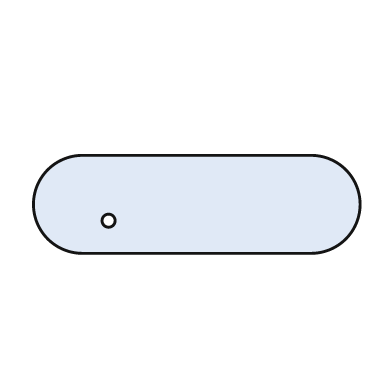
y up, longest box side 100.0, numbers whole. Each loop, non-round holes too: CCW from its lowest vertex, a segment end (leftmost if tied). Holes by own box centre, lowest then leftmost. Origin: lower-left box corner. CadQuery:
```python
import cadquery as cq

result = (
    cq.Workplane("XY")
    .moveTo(15.0, 0.0)
    .lineTo(85.0, 0.0)
    .threePointArc((100.0, 15.0), (85.0, 30.0))
    .lineTo(15.0, 30.0)
    .threePointArc((0.0, 15.0), (15.0, 0.0))
    .close()
    .moveTo(23.0, 10.0)
    .circle(2.0)
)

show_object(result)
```